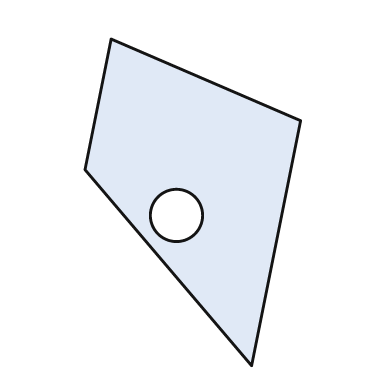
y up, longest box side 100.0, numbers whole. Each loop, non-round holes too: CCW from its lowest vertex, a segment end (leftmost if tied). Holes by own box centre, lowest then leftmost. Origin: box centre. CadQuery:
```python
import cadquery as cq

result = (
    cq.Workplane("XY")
    .moveTo(18.0, -50.0)
    .lineTo(33.0, 25.0)
    .lineTo(-25.0, 50.0)
    .lineTo(-33.0, 10.0)
    .close()
    .moveTo(-5.0, -4.0)
    .circle(8.0)
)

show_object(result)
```